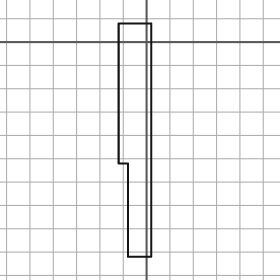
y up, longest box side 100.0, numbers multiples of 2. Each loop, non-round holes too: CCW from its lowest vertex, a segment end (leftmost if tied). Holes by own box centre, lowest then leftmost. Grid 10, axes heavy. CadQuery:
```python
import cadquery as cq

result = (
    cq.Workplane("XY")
    .moveTo(-8.0, -92.0)
    .lineTo(2.0, -92.0)
    .lineTo(2.0, 8.0)
    .lineTo(-12.0, 8.0)
    .lineTo(-12.0, -52.0)
    .lineTo(-8.0, -52.0)
    .close()
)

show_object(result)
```